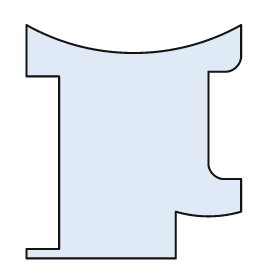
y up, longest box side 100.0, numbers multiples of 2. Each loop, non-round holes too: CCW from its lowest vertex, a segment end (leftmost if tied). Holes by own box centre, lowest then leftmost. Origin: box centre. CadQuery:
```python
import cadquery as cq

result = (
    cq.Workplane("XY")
    .moveTo(-46.0, -50.0)
    .lineTo(18.0, -50.0)
    .lineTo(18.0, -30.0)
    .threePointArc((32.0, -32.0), (46.0, -30.0))
    .lineTo(46.0, -16.0)
    .lineTo(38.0, -16.0)
    .threePointArc((34.0, -14.0), (32.0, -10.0))
    .lineTo(32.0, 30.0)
    .lineTo(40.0, 30.0)
    .threePointArc((44.0, 32.0), (46.0, 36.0))
    .lineTo(46.0, 50.0)
    .threePointArc((0.0, 38.0), (-46.0, 50.0))
    .lineTo(-46.0, 28.0)
    .lineTo(-32.0, 28.0)
    .lineTo(-32.0, -46.0)
    .lineTo(-46.0, -46.0)
    .close()
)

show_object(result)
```